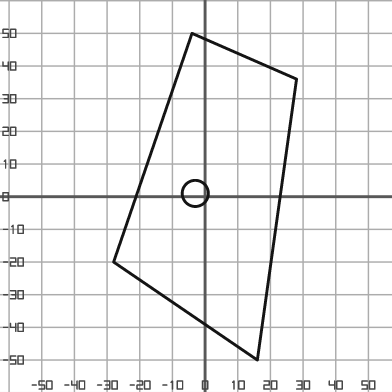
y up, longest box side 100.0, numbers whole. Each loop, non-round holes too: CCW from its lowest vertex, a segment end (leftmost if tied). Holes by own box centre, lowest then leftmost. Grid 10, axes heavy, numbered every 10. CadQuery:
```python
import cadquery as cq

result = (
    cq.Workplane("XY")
    .moveTo(16.0, -50.0)
    .lineTo(28.0, 36.0)
    .lineTo(-4.0, 50.0)
    .lineTo(-28.0, -20.0)
    .close()
    .moveTo(-3.0, 1.0)
    .circle(4.0)
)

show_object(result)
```